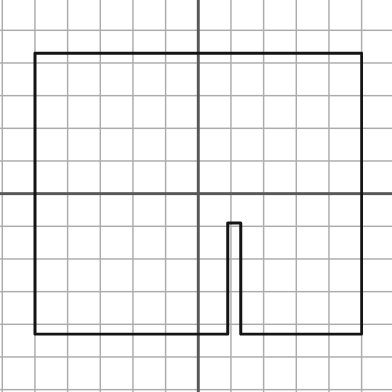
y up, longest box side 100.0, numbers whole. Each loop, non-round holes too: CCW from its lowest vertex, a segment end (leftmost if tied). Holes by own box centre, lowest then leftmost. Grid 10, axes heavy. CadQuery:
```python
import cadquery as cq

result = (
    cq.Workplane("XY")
    .moveTo(-50.0, -43.0)
    .lineTo(9.0, -43.0)
    .lineTo(9.0, -9.0)
    .lineTo(13.0, -9.0)
    .lineTo(13.0, -43.0)
    .lineTo(50.0, -43.0)
    .lineTo(50.0, 43.0)
    .lineTo(-50.0, 43.0)
    .close()
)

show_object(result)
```